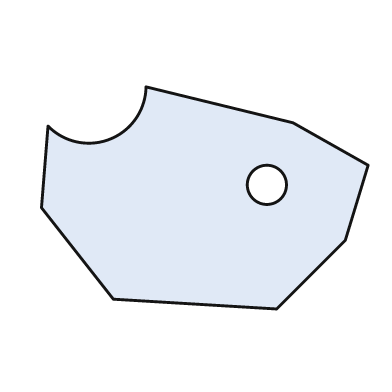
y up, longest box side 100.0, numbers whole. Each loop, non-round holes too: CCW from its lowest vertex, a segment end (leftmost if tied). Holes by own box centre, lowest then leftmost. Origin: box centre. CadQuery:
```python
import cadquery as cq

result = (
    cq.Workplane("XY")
    .moveTo(22.0, -34.0)
    .lineTo(43.0, -13.0)
    .lineTo(50.0, 10.0)
    .lineTo(27.0, 23.0)
    .lineTo(-18.0, 34.0)
    .threePointArc((-29.0, 18.0), (-48.0, 22.0))
    .lineTo(-50.0, -3.0)
    .lineTo(-28.0, -31.0)
    .close()
    .moveTo(19.0, 4.0)
    .circle(6.0)
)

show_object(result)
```